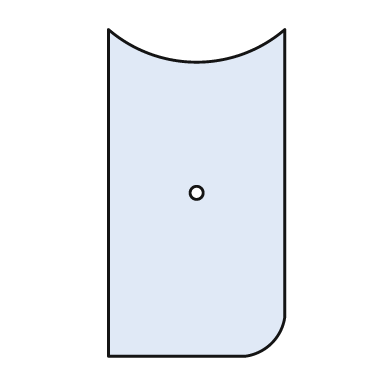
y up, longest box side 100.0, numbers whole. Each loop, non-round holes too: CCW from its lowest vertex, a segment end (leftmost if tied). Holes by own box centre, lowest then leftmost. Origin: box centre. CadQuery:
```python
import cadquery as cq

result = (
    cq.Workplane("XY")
    .moveTo(-27.0, -50.0)
    .lineTo(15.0, -50.0)
    .threePointArc((23.0, -46.0), (27.0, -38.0))
    .lineTo(27.0, 50.0)
    .threePointArc((0.0, 40.0), (-27.0, 50.0))
    .close()
    .moveTo(0.0, 0.0)
    .circle(2.0)
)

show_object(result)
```